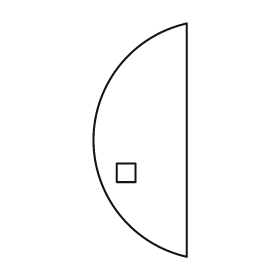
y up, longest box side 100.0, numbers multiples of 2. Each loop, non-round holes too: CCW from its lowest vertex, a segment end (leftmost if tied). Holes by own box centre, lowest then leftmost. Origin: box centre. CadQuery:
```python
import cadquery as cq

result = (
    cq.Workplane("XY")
    .moveTo(20.0, -50.0)
    .lineTo(20.0, 50.0)
    .threePointArc((-20.0, 0.0), (20.0, -50.0))
    .close()
    .moveTo(-10.0, -18.0)
    .lineTo(-2.0, -18.0)
    .lineTo(-2.0, -10.0)
    .lineTo(-10.0, -10.0)
    .close()
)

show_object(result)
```